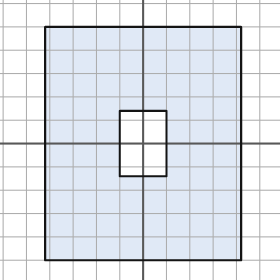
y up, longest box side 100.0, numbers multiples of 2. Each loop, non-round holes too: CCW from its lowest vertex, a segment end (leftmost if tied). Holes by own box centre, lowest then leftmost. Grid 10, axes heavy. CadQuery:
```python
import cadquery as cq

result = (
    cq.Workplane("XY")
    .moveTo(-42.0, -50.0)
    .lineTo(42.0, -50.0)
    .lineTo(42.0, 50.0)
    .lineTo(-42.0, 50.0)
    .close()
    .moveTo(-10.0, -14.0)
    .lineTo(10.0, -14.0)
    .lineTo(10.0, 14.0)
    .lineTo(-10.0, 14.0)
    .close()
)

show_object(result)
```